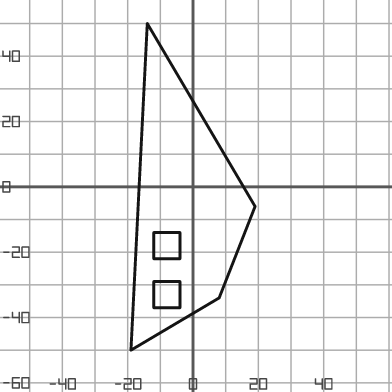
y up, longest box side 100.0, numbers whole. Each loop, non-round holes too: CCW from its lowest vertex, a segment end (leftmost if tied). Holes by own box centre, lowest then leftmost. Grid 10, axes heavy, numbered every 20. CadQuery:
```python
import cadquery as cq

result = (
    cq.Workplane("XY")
    .moveTo(-19.0, -50.0)
    .lineTo(8.0, -34.0)
    .lineTo(19.0, -6.0)
    .lineTo(-14.0, 50.0)
    .close()
    .moveTo(-12.0, -37.0)
    .lineTo(-4.0, -37.0)
    .lineTo(-4.0, -29.0)
    .lineTo(-12.0, -29.0)
    .close()
    .moveTo(-12.0, -22.0)
    .lineTo(-4.0, -22.0)
    .lineTo(-4.0, -14.0)
    .lineTo(-12.0, -14.0)
    .close()
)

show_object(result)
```